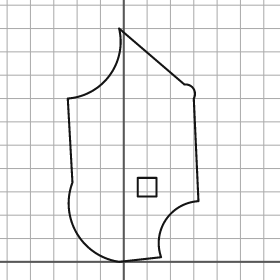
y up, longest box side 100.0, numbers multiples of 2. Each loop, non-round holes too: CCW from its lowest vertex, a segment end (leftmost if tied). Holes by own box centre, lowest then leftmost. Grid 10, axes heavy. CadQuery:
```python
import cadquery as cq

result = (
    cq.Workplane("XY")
    .moveTo(-2.0, 0.0)
    .lineTo(16.0, 2.0)
    .threePointArc((18.0, 18.0), (32.0, 26.0))
    .lineTo(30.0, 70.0)
    .threePointArc((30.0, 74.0), (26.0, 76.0))
    .lineTo(-2.0, 100.0)
    .threePointArc((-6.0, 80.0), (-24.0, 70.0))
    .lineTo(-22.0, 34.0)
    .threePointArc((-20.0, 12.0), (-2.0, 0.0))
    .close()
    .moveTo(6.0, 28.0)
    .lineTo(14.0, 28.0)
    .lineTo(14.0, 36.0)
    .lineTo(6.0, 36.0)
    .close()
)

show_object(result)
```